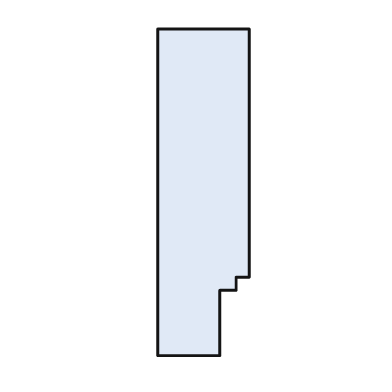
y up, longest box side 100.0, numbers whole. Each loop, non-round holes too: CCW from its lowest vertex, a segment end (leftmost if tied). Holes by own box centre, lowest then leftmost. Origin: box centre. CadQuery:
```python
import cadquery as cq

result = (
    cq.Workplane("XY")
    .moveTo(-14.0, -50.0)
    .lineTo(5.0, -50.0)
    .lineTo(5.0, -30.0)
    .lineTo(10.0, -30.0)
    .lineTo(10.0, -26.0)
    .lineTo(14.0, -26.0)
    .lineTo(14.0, 50.0)
    .lineTo(-14.0, 50.0)
    .close()
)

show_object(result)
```